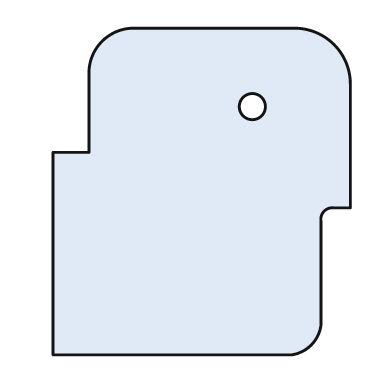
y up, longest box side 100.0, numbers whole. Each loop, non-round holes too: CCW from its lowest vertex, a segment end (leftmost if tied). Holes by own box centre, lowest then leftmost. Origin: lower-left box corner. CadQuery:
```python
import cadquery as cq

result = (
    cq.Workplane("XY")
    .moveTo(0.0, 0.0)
    .lineTo(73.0, 0.0)
    .threePointArc((79.0, 3.0), (82.0, 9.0))
    .lineTo(82.0, 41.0)
    .threePointArc((83.0, 44.0), (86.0, 45.0))
    .lineTo(91.0, 45.0)
    .lineTo(91.0, 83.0)
    .threePointArc((86.0, 95.0), (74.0, 100.0))
    .lineTo(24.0, 100.0)
    .threePointArc((15.0, 96.0), (11.0, 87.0))
    .lineTo(11.0, 62.0)
    .lineTo(0.0, 62.0)
    .close()
    .moveTo(61.0, 76.0)
    .circle(4.0)
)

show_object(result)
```